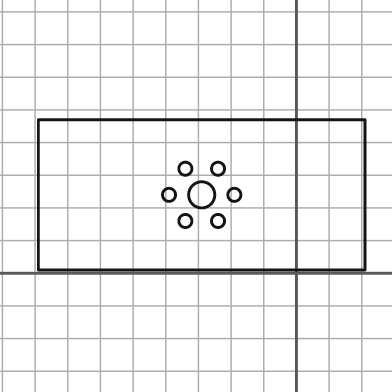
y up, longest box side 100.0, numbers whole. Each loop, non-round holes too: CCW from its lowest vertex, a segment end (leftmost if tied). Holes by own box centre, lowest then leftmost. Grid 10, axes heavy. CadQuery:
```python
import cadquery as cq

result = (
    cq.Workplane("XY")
    .moveTo(-79.0, 1.0)
    .lineTo(21.0, 1.0)
    .lineTo(21.0, 47.0)
    .lineTo(-79.0, 47.0)
    .close()
    .moveTo(-34.0, 16.0)
    .circle(2.0)
    .moveTo(-24.0, 16.0)
    .circle(2.0)
    .moveTo(-39.0, 24.0)
    .circle(2.0)
    .moveTo(-29.0, 24.0)
    .circle(4.0)
    .moveTo(-19.0, 24.0)
    .circle(2.0)
    .moveTo(-34.0, 32.0)
    .circle(2.0)
    .moveTo(-24.0, 32.0)
    .circle(2.0)
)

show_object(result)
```